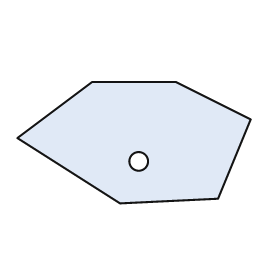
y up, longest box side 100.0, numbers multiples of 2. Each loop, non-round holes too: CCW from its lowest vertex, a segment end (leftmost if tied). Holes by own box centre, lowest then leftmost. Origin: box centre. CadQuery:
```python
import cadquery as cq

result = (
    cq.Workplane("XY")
    .moveTo(-6.0, -26.0)
    .lineTo(36.0, -24.0)
    .lineTo(50.0, 10.0)
    .lineTo(18.0, 26.0)
    .lineTo(-18.0, 26.0)
    .lineTo(-50.0, 2.0)
    .close()
    .moveTo(2.0, -8.0)
    .circle(4.0)
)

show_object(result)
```